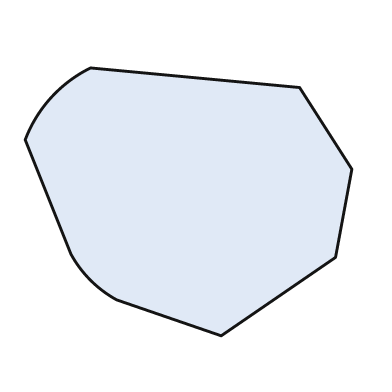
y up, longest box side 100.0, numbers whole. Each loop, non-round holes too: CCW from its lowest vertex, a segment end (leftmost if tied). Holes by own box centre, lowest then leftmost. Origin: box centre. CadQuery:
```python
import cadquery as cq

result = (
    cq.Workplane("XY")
    .moveTo(10.0, -41.0)
    .lineTo(45.0, -17.0)
    .lineTo(50.0, 10.0)
    .lineTo(34.0, 35.0)
    .lineTo(-30.0, 41.0)
    .threePointArc((-42.0, 32.0), (-50.0, 19.0))
    .lineTo(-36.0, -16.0)
    .threePointArc((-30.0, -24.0), (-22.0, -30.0))
    .close()
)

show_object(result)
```